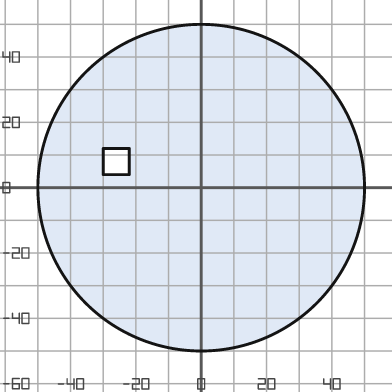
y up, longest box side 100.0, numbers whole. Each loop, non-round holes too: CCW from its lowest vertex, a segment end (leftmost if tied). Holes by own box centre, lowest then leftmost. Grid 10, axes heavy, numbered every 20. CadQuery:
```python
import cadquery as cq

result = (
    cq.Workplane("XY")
    .moveTo(0.0, 0.0)
    .circle(50.0)
    .moveTo(-30.0, 4.0)
    .lineTo(-22.0, 4.0)
    .lineTo(-22.0, 12.0)
    .lineTo(-30.0, 12.0)
    .close()
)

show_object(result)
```